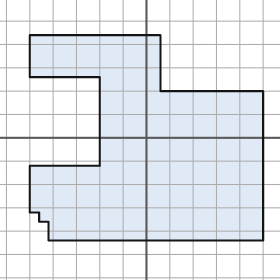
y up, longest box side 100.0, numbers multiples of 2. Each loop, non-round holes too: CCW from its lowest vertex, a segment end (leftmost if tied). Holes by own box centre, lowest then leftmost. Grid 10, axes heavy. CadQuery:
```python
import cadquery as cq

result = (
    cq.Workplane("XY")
    .moveTo(-42.0, -44.0)
    .lineTo(50.0, -44.0)
    .lineTo(50.0, 20.0)
    .lineTo(6.0, 20.0)
    .lineTo(6.0, 44.0)
    .lineTo(-50.0, 44.0)
    .lineTo(-50.0, 26.0)
    .lineTo(-20.0, 26.0)
    .lineTo(-20.0, -12.0)
    .lineTo(-50.0, -12.0)
    .lineTo(-50.0, -32.0)
    .lineTo(-46.0, -32.0)
    .lineTo(-46.0, -36.0)
    .lineTo(-42.0, -36.0)
    .close()
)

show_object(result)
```